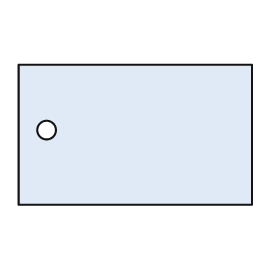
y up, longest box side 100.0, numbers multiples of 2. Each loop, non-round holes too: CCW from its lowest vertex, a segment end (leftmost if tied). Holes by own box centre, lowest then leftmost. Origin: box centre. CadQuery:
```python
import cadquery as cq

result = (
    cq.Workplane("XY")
    .moveTo(-50.0, -30.0)
    .lineTo(50.0, -30.0)
    .lineTo(50.0, 30.0)
    .lineTo(-50.0, 30.0)
    .close()
    .moveTo(-38.0, 2.0)
    .circle(4.0)
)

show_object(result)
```